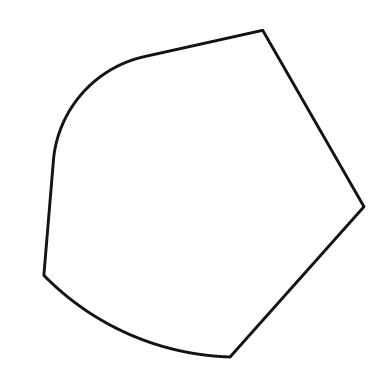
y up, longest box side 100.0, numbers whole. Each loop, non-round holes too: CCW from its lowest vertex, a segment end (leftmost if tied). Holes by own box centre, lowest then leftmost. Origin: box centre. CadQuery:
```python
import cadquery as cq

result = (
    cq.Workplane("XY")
    .moveTo(8.0, -50.0)
    .lineTo(49.0, -4.0)
    .lineTo(18.0, 50.0)
    .lineTo(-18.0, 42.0)
    .threePointArc((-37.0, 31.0), (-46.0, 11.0))
    .lineTo(-49.0, -25.0)
    .threePointArc((-23.0, -43.0), (8.0, -50.0))
    .close()
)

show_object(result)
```